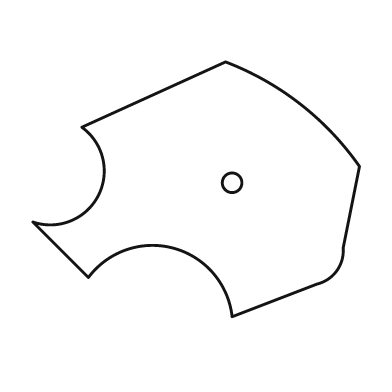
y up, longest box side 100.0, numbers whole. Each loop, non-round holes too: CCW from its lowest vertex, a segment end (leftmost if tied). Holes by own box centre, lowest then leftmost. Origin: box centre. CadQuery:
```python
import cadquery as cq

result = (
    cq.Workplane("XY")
    .moveTo(11.0, -39.0)
    .lineTo(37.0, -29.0)
    .threePointArc((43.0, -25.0), (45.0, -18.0))
    .lineTo(50.0, 7.0)
    .threePointArc((32.0, 26.0), (9.0, 39.0))
    .lineTo(-35.0, 19.0)
    .threePointArc((-30.0, -2.0), (-50.0, -10.0))
    .lineTo(-33.0, -27.0)
    .threePointArc((-7.0, -18.0), (11.0, -39.0))
    .close()
    .moveTo(11.0, 2.0)
    .circle(3.0)
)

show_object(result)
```